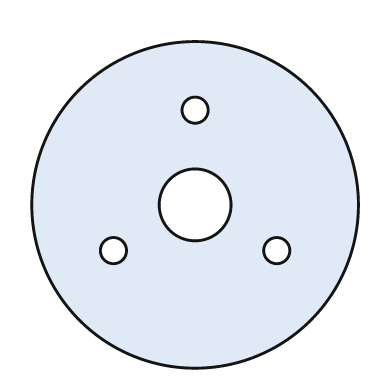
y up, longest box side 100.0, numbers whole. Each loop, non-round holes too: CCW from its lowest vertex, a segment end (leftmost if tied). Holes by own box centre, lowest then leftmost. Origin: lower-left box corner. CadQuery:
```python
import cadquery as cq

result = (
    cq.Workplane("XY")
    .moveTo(50.0, 50.0)
    .circle(50.0)
    .moveTo(25.0, 36.0)
    .circle(4.0)
    .moveTo(75.0, 36.0)
    .circle(4.0)
    .moveTo(50.0, 50.0)
    .circle(11.0)
    .moveTo(50.0, 79.0)
    .circle(4.0)
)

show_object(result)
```